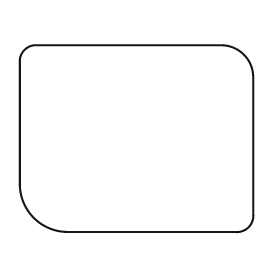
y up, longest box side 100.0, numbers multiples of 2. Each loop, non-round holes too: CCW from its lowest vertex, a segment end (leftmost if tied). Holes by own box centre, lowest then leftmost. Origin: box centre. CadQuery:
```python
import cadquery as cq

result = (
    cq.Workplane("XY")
    .moveTo(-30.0, -40.0)
    .lineTo(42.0, -40.0)
    .threePointArc((48.0, -38.0), (50.0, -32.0))
    .lineTo(50.0, 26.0)
    .threePointArc((46.0, 36.0), (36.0, 40.0))
    .lineTo(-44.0, 40.0)
    .threePointArc((-48.0, 38.0), (-50.0, 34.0))
    .lineTo(-50.0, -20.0)
    .threePointArc((-44.0, -34.0), (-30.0, -40.0))
    .close()
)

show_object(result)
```